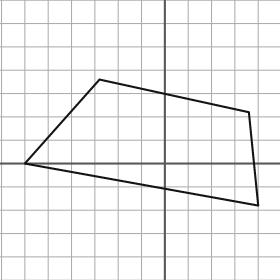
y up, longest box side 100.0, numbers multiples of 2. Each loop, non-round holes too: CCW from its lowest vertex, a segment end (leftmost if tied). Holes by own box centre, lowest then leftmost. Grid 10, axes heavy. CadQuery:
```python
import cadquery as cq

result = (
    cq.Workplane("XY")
    .moveTo(40.0, -18.0)
    .lineTo(36.0, 22.0)
    .lineTo(-28.0, 36.0)
    .lineTo(-60.0, 0.0)
    .close()
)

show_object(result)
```